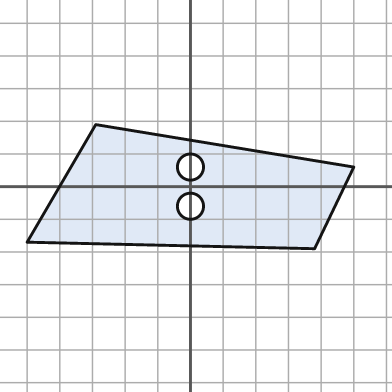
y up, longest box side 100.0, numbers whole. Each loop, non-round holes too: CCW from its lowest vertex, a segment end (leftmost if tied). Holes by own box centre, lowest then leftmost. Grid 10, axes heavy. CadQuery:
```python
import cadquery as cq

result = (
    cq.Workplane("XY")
    .moveTo(38.0, -19.0)
    .lineTo(50.0, 6.0)
    .lineTo(-29.0, 19.0)
    .lineTo(-50.0, -17.0)
    .close()
    .moveTo(0.0, -6.0)
    .circle(4.0)
    .moveTo(0.0, 6.0)
    .circle(4.0)
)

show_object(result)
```